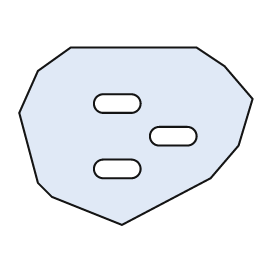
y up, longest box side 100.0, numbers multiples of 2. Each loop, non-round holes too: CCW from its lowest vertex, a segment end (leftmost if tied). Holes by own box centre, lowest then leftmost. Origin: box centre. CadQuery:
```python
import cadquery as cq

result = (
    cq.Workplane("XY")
    .moveTo(-6.0, -38.0)
    .lineTo(32.0, -18.0)
    .lineTo(44.0, -4.0)
    .lineTo(50.0, 16.0)
    .lineTo(38.0, 30.0)
    .lineTo(26.0, 38.0)
    .lineTo(-28.0, 38.0)
    .lineTo(-42.0, 28.0)
    .lineTo(-50.0, 10.0)
    .lineTo(-42.0, -20.0)
    .lineTo(-36.0, -26.0)
    .close()
    .moveTo(-14.0, -18.0)
    .lineTo(-2.0, -18.0)
    .threePointArc((2.0, -14.0), (-2.0, -10.0))
    .lineTo(-14.0, -10.0)
    .threePointArc((-18.0, -14.0), (-14.0, -18.0))
    .close()
    .moveTo(10.0, -4.0)
    .lineTo(22.0, -4.0)
    .threePointArc((26.0, 0.0), (22.0, 4.0))
    .lineTo(10.0, 4.0)
    .threePointArc((6.0, 0.0), (10.0, -4.0))
    .close()
    .moveTo(-14.0, 10.0)
    .lineTo(-2.0, 10.0)
    .threePointArc((2.0, 14.0), (-2.0, 18.0))
    .lineTo(-14.0, 18.0)
    .threePointArc((-18.0, 14.0), (-14.0, 10.0))
    .close()
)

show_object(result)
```